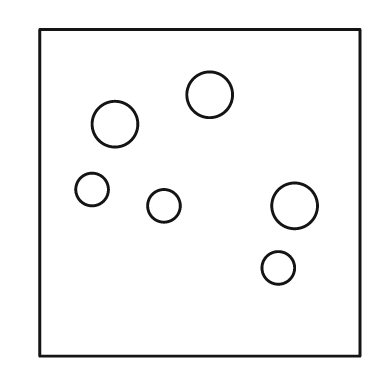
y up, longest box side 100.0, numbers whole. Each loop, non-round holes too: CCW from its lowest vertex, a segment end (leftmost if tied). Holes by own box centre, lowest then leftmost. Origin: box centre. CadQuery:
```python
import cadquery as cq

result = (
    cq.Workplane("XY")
    .moveTo(-49.0, -50.0)
    .lineTo(49.0, -50.0)
    .lineTo(49.0, 50.0)
    .lineTo(-49.0, 50.0)
    .close()
    .moveTo(24.0, -23.0)
    .circle(5.0)
    .moveTo(-11.0, -4.0)
    .circle(5.0)
    .moveTo(29.0, -4.0)
    .circle(7.0)
    .moveTo(-33.0, 1.0)
    .circle(5.0)
    .moveTo(-26.0, 21.0)
    .circle(7.0)
    .moveTo(3.0, 30.0)
    .circle(7.0)
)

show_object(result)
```